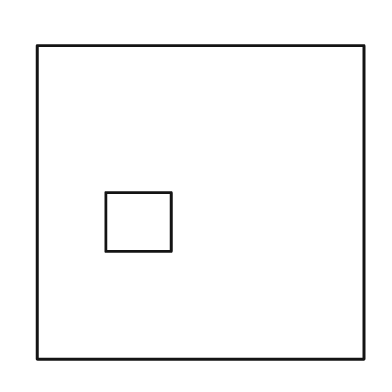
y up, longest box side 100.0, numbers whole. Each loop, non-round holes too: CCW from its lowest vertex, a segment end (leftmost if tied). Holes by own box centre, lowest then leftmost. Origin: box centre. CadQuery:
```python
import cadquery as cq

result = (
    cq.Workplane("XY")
    .moveTo(-50.0, -48.0)
    .lineTo(50.0, -48.0)
    .lineTo(50.0, 48.0)
    .lineTo(-50.0, 48.0)
    .close()
    .moveTo(-29.0, -15.0)
    .lineTo(-9.0, -15.0)
    .lineTo(-9.0, 3.0)
    .lineTo(-29.0, 3.0)
    .close()
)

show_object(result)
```